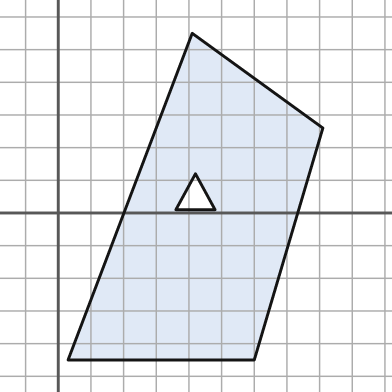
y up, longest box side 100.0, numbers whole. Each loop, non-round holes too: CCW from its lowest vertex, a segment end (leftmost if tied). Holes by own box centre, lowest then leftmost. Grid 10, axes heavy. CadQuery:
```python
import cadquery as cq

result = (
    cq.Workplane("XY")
    .moveTo(3.0, -45.0)
    .lineTo(60.0, -45.0)
    .lineTo(81.0, 26.0)
    .lineTo(41.0, 55.0)
    .close()
    .moveTo(36.0, 1.0)
    .lineTo(48.0, 1.0)
    .lineTo(42.0, 12.0)
    .close()
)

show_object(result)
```